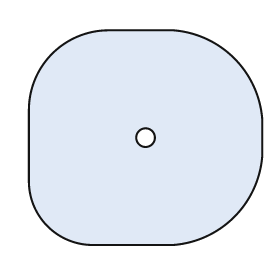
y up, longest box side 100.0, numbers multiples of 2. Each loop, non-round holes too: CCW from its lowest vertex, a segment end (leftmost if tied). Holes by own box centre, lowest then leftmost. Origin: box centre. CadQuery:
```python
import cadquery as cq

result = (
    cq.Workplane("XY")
    .moveTo(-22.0, -46.0)
    .lineTo(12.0, -46.0)
    .threePointArc((38.0, -34.0), (50.0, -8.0))
    .lineTo(50.0, 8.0)
    .threePointArc((38.0, 34.0), (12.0, 46.0))
    .lineTo(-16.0, 46.0)
    .threePointArc((-40.0, 36.0), (-50.0, 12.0))
    .lineTo(-50.0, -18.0)
    .threePointArc((-42.0, -38.0), (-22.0, -46.0))
    .close()
    .moveTo(0.0, 0.0)
    .circle(4.0)
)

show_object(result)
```